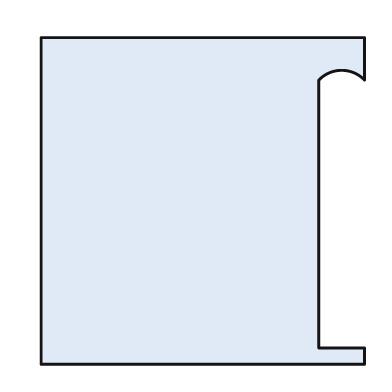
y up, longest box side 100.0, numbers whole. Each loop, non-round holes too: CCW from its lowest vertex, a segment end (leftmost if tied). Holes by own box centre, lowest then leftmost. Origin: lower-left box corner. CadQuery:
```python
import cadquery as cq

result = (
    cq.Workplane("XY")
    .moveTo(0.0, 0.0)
    .lineTo(99.0, 0.0)
    .lineTo(99.0, 5.0)
    .lineTo(85.0, 5.0)
    .lineTo(85.0, 87.0)
    .threePointArc((92.0, 90.0), (99.0, 87.0))
    .lineTo(99.0, 100.0)
    .lineTo(0.0, 100.0)
    .close()
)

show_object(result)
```